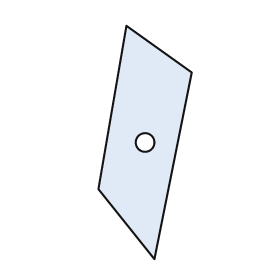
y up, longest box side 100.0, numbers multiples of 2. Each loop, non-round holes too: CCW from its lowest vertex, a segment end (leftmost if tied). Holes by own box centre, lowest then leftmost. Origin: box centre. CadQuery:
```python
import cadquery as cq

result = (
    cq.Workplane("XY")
    .moveTo(4.0, -50.0)
    .lineTo(20.0, 30.0)
    .lineTo(-8.0, 50.0)
    .lineTo(-20.0, -20.0)
    .close()
    .moveTo(0.0, 0.0)
    .circle(4.0)
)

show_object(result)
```